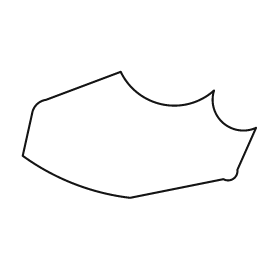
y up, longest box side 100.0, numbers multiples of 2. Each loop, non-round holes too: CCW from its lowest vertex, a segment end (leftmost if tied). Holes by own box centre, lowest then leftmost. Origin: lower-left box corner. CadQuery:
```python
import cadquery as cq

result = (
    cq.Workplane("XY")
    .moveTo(46.0, 0.0)
    .lineTo(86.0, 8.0)
    .threePointArc((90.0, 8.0), (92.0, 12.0))
    .lineTo(100.0, 30.0)
    .threePointArc((86.0, 32.0), (82.0, 46.0))
    .threePointArc((60.0, 40.0), (42.0, 54.0))
    .lineTo(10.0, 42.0)
    .threePointArc((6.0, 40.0), (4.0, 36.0))
    .lineTo(0.0, 18.0)
    .threePointArc((22.0, 6.0), (46.0, 0.0))
    .close()
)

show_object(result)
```